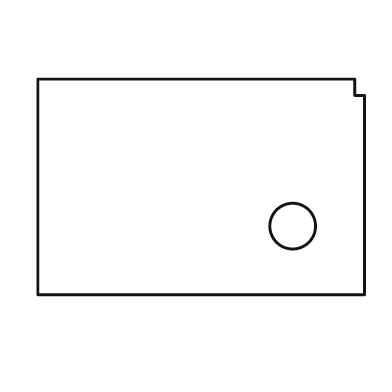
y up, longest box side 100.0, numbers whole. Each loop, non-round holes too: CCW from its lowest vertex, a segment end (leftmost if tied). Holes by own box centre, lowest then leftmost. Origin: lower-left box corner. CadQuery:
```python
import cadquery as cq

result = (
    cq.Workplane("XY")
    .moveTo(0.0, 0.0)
    .lineTo(100.0, 0.0)
    .lineTo(100.0, 61.0)
    .lineTo(97.0, 61.0)
    .lineTo(97.0, 66.0)
    .lineTo(0.0, 66.0)
    .close()
    .moveTo(78.0, 21.0)
    .circle(7.0)
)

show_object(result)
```